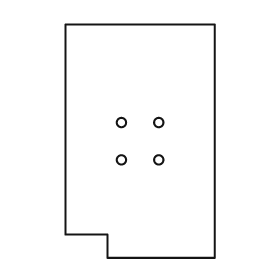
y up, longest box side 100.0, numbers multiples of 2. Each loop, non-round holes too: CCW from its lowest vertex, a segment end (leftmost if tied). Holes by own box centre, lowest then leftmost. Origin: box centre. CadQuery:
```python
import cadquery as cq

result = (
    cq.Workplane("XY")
    .moveTo(-14.0, -50.0)
    .lineTo(32.0, -50.0)
    .lineTo(32.0, 50.0)
    .lineTo(-32.0, 50.0)
    .lineTo(-32.0, -40.0)
    .lineTo(-14.0, -40.0)
    .close()
    .moveTo(-8.0, -8.0)
    .circle(2.0)
    .moveTo(8.0, -8.0)
    .circle(2.0)
    .moveTo(-8.0, 8.0)
    .circle(2.0)
    .moveTo(8.0, 8.0)
    .circle(2.0)
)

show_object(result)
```